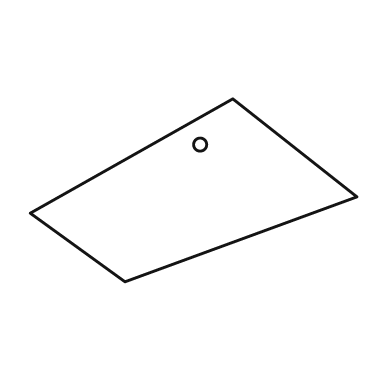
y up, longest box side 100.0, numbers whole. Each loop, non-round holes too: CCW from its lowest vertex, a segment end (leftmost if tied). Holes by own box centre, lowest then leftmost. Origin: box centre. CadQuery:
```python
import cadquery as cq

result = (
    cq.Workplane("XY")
    .moveTo(-21.0, -28.0)
    .lineTo(50.0, -2.0)
    .lineTo(12.0, 28.0)
    .lineTo(-50.0, -7.0)
    .close()
    .moveTo(2.0, 14.0)
    .circle(2.0)
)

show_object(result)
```